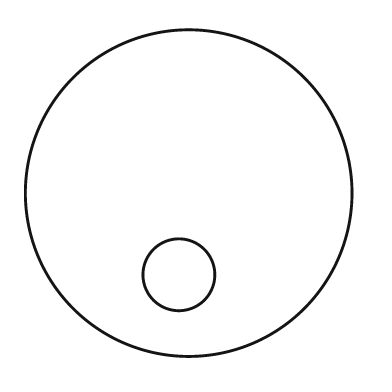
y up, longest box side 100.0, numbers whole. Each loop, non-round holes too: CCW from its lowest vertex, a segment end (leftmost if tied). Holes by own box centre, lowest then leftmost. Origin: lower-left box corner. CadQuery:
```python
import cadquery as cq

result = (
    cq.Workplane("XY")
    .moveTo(50.0, 50.0)
    .circle(50.0)
    .moveTo(47.0, 25.0)
    .circle(11.0)
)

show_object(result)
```